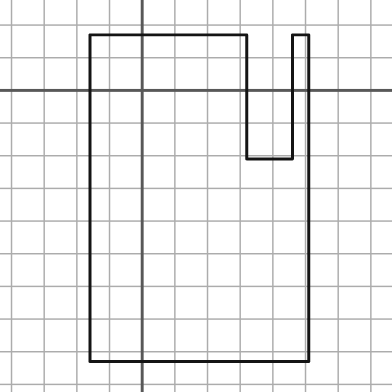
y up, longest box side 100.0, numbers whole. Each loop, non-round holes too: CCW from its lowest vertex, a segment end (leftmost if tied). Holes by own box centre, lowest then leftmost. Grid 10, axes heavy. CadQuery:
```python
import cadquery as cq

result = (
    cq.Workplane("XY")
    .moveTo(-16.0, -83.0)
    .lineTo(51.0, -83.0)
    .lineTo(51.0, 17.0)
    .lineTo(46.0, 17.0)
    .lineTo(46.0, -21.0)
    .lineTo(32.0, -21.0)
    .lineTo(32.0, 17.0)
    .lineTo(-16.0, 17.0)
    .close()
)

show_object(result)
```